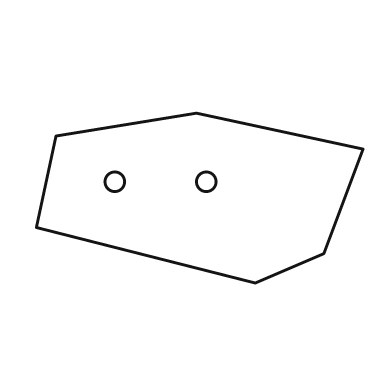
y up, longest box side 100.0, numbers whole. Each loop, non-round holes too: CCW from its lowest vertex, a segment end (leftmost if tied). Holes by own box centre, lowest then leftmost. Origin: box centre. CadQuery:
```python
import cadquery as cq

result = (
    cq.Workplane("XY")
    .moveTo(17.0, -26.0)
    .lineTo(38.0, -17.0)
    .lineTo(50.0, 15.0)
    .lineTo(-1.0, 26.0)
    .lineTo(-44.0, 19.0)
    .lineTo(-50.0, -9.0)
    .close()
    .moveTo(-26.0, 5.0)
    .circle(3.0)
    .moveTo(2.0, 5.0)
    .circle(3.0)
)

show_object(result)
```